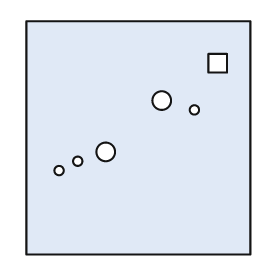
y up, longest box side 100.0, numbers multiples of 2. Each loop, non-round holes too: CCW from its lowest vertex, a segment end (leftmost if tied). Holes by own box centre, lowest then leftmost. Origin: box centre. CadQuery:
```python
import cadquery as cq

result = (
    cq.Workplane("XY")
    .moveTo(-48.0, -50.0)
    .lineTo(48.0, -50.0)
    .lineTo(48.0, 50.0)
    .lineTo(-48.0, 50.0)
    .close()
    .moveTo(-34.0, -14.0)
    .circle(2.0)
    .moveTo(-26.0, -10.0)
    .circle(2.0)
    .moveTo(-14.0, -6.0)
    .circle(4.0)
    .moveTo(24.0, 12.0)
    .circle(2.0)
    .moveTo(10.0, 16.0)
    .circle(4.0)
    .moveTo(30.0, 28.0)
    .lineTo(38.0, 28.0)
    .lineTo(38.0, 36.0)
    .lineTo(30.0, 36.0)
    .close()
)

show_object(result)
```